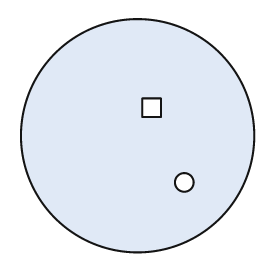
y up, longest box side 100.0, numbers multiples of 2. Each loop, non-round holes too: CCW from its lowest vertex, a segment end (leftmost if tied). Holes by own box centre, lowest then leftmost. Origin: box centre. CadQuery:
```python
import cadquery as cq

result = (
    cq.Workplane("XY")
    .moveTo(0.0, 0.0)
    .circle(50.0)
    .moveTo(20.0, -20.0)
    .circle(4.0)
    .moveTo(2.0, 8.0)
    .lineTo(10.0, 8.0)
    .lineTo(10.0, 16.0)
    .lineTo(2.0, 16.0)
    .close()
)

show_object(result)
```